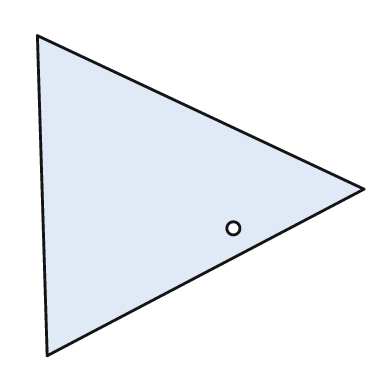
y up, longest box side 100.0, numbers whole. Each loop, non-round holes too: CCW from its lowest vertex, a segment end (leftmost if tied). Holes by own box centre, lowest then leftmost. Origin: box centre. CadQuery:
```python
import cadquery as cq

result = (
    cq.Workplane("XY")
    .moveTo(-47.0, -49.0)
    .lineTo(50.0, 2.0)
    .lineTo(-50.0, 49.0)
    .close()
    .moveTo(10.0, -10.0)
    .circle(2.0)
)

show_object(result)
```